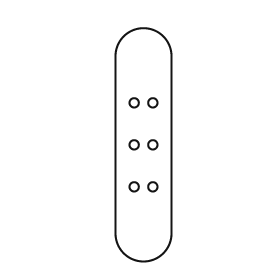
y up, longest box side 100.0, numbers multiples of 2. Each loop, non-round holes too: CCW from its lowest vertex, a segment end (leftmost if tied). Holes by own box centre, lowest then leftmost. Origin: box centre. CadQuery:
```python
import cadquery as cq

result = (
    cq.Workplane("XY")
    .moveTo(-12.0, -38.0)
    .threePointArc((0.0, -50.0), (12.0, -38.0))
    .lineTo(12.0, 38.0)
    .threePointArc((0.0, 50.0), (-12.0, 38.0))
    .close()
    .moveTo(-4.0, -18.0)
    .circle(2.0)
    .moveTo(4.0, -18.0)
    .circle(2.0)
    .moveTo(-4.0, 0.0)
    .circle(2.0)
    .moveTo(4.0, 0.0)
    .circle(2.0)
    .moveTo(-4.0, 18.0)
    .circle(2.0)
    .moveTo(4.0, 18.0)
    .circle(2.0)
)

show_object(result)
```